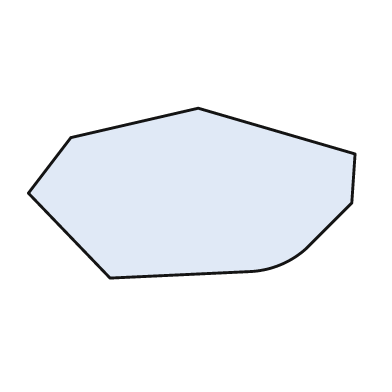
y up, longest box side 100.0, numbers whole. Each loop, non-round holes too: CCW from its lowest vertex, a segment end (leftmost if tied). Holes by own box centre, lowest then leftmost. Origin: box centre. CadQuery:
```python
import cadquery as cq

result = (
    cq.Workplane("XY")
    .moveTo(-25.0, -26.0)
    .lineTo(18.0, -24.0)
    .threePointArc((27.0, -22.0), (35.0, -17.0))
    .lineTo(49.0, -3.0)
    .lineTo(50.0, 12.0)
    .lineTo(2.0, 26.0)
    .lineTo(-37.0, 17.0)
    .lineTo(-50.0, 0.0)
    .close()
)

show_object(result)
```